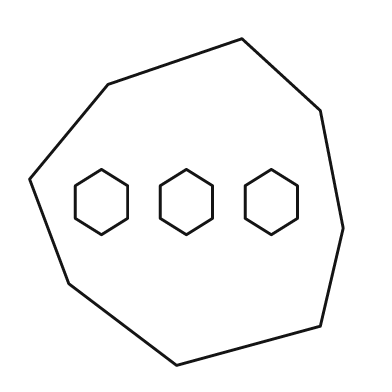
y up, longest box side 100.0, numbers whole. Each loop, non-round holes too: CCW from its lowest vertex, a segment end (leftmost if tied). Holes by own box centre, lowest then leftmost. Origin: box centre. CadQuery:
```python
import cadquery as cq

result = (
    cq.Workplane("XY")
    .moveTo(-3.0, -50.0)
    .lineTo(41.0, -38.0)
    .lineTo(48.0, -8.0)
    .lineTo(41.0, 28.0)
    .lineTo(17.0, 50.0)
    .lineTo(-24.0, 36.0)
    .lineTo(-48.0, 7.0)
    .lineTo(-36.0, -25.0)
    .close()
    .moveTo(-26.0, -10.0)
    .lineTo(-18.0, -5.0)
    .lineTo(-18.0, 5.0)
    .lineTo(-26.0, 10.0)
    .lineTo(-34.0, 5.0)
    .lineTo(-34.0, -5.0)
    .close()
    .moveTo(0.0, -10.0)
    .lineTo(8.0, -5.0)
    .lineTo(8.0, 5.0)
    .lineTo(0.0, 10.0)
    .lineTo(-8.0, 5.0)
    .lineTo(-8.0, -5.0)
    .close()
    .moveTo(26.0, -10.0)
    .lineTo(34.0, -5.0)
    .lineTo(34.0, 5.0)
    .lineTo(26.0, 10.0)
    .lineTo(18.0, 5.0)
    .lineTo(18.0, -5.0)
    .close()
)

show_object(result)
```